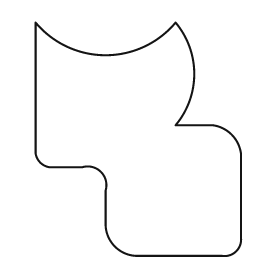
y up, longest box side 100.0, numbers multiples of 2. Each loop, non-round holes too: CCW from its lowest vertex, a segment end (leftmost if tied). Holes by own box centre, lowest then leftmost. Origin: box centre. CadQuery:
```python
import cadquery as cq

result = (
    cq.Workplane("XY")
    .moveTo(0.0, -50.0)
    .lineTo(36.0, -50.0)
    .threePointArc((42.0, -48.0), (44.0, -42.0))
    .lineTo(44.0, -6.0)
    .threePointArc((40.0, 2.0), (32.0, 6.0))
    .lineTo(16.0, 6.0)
    .threePointArc((24.0, 28.0), (16.0, 50.0))
    .threePointArc((-14.0, 36.0), (-44.0, 50.0))
    .lineTo(-44.0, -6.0)
    .threePointArc((-42.0, -10.0), (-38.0, -12.0))
    .lineTo(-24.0, -12.0)
    .threePointArc((-16.0, -14.0), (-14.0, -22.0))
    .lineTo(-14.0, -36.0)
    .threePointArc((-10.0, -46.0), (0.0, -50.0))
    .close()
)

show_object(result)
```